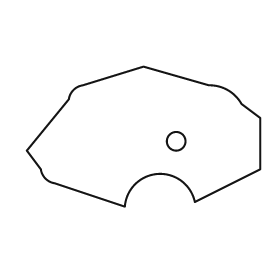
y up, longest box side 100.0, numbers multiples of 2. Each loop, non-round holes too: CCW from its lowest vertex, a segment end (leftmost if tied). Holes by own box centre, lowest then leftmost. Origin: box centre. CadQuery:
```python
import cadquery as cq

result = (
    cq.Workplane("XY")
    .moveTo(-8.0, -30.0)
    .threePointArc((6.0, -16.0), (22.0, -28.0))
    .lineTo(50.0, -14.0)
    .lineTo(50.0, 8.0)
    .lineTo(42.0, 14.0)
    .threePointArc((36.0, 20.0), (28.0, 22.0))
    .lineTo(0.0, 30.0)
    .lineTo(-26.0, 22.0)
    .threePointArc((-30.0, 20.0), (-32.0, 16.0))
    .lineTo(-50.0, -6.0)
    .lineTo(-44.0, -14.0)
    .threePointArc((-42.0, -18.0), (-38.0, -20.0))
    .close()
    .moveTo(14.0, -2.0)
    .circle(4.0)
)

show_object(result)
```